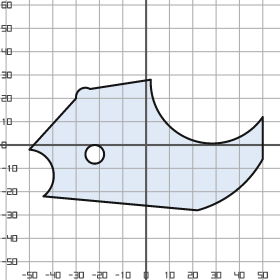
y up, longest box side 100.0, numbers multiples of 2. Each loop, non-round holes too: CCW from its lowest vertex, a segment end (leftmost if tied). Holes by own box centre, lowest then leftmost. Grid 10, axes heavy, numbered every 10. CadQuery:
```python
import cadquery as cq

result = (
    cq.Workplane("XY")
    .moveTo(22.0, -28.0)
    .threePointArc((38.0, -20.0), (50.0, -6.0))
    .lineTo(50.0, 12.0)
    .threePointArc((20.0, 2.0), (2.0, 28.0))
    .lineTo(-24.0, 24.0)
    .threePointArc((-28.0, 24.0), (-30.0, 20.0))
    .lineTo(-50.0, -2.0)
    .threePointArc((-40.0, -10.0), (-44.0, -22.0))
    .close()
    .moveTo(-22.0, -4.0)
    .circle(4.0)
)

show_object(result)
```